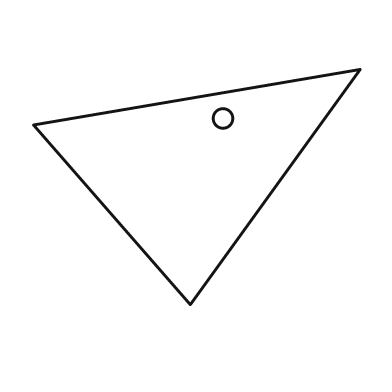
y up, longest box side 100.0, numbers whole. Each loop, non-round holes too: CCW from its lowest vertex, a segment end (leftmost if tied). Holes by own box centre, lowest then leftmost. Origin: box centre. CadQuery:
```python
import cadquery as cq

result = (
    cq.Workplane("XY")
    .moveTo(-2.0, -36.0)
    .lineTo(50.0, 36.0)
    .lineTo(-50.0, 19.0)
    .close()
    .moveTo(8.0, 21.0)
    .circle(3.0)
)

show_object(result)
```